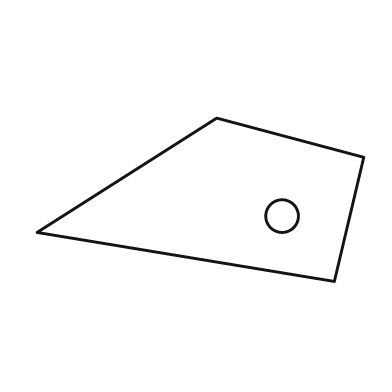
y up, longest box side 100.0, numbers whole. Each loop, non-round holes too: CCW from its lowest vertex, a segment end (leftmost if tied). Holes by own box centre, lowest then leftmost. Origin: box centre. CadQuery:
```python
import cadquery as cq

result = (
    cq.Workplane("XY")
    .moveTo(41.0, -25.0)
    .lineTo(50.0, 13.0)
    .lineTo(5.0, 25.0)
    .lineTo(-50.0, -10.0)
    .close()
    .moveTo(25.0, -5.0)
    .circle(5.0)
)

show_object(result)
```